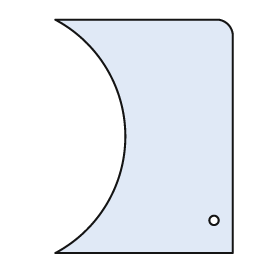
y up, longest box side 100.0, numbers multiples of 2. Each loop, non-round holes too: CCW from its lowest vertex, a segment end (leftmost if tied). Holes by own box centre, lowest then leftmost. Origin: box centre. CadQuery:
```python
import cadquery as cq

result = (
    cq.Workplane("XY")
    .moveTo(-38.0, -50.0)
    .lineTo(38.0, -50.0)
    .lineTo(38.0, 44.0)
    .threePointArc((36.0, 48.0), (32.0, 50.0))
    .lineTo(-38.0, 50.0)
    .threePointArc((-8.0, 0.0), (-38.0, -50.0))
    .close()
    .moveTo(30.0, -36.0)
    .circle(2.0)
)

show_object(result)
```